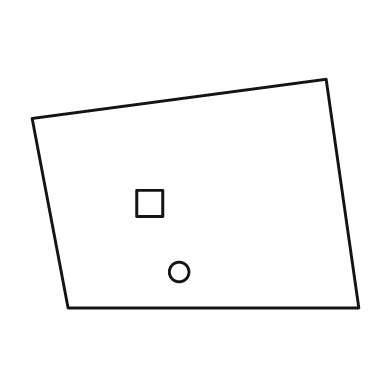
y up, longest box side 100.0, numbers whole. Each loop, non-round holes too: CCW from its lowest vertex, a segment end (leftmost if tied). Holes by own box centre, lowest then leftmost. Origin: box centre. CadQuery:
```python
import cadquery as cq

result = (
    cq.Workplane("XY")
    .moveTo(-39.0, -35.0)
    .lineTo(50.0, -35.0)
    .lineTo(40.0, 35.0)
    .lineTo(-50.0, 23.0)
    .close()
    .moveTo(-5.0, -24.0)
    .circle(3.0)
    .moveTo(-18.0, -7.0)
    .lineTo(-10.0, -7.0)
    .lineTo(-10.0, 1.0)
    .lineTo(-18.0, 1.0)
    .close()
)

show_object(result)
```